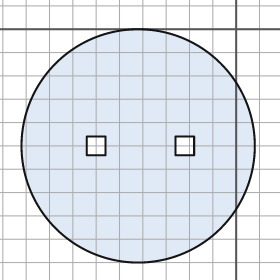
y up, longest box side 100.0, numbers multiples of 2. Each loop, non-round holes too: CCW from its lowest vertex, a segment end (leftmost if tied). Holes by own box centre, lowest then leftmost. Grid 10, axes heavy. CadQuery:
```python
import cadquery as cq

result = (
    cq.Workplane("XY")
    .moveTo(-42.0, -50.0)
    .circle(50.0)
    .moveTo(-64.0, -54.0)
    .lineTo(-56.0, -54.0)
    .lineTo(-56.0, -46.0)
    .lineTo(-64.0, -46.0)
    .close()
    .moveTo(-26.0, -54.0)
    .lineTo(-18.0, -54.0)
    .lineTo(-18.0, -46.0)
    .lineTo(-26.0, -46.0)
    .close()
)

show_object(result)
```